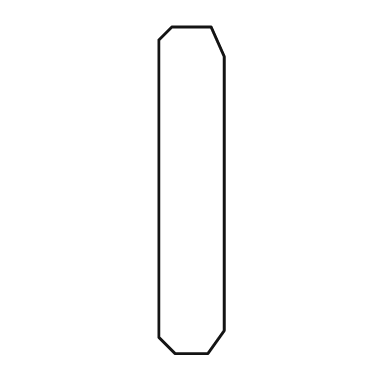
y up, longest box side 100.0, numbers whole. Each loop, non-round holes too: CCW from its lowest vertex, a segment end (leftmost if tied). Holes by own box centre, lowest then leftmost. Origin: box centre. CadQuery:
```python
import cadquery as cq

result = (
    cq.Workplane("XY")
    .moveTo(-5.0, -50.0)
    .lineTo(5.0, -50.0)
    .lineTo(10.0, -43.0)
    .lineTo(10.0, 41.0)
    .lineTo(6.0, 50.0)
    .lineTo(-6.0, 50.0)
    .lineTo(-10.0, 46.0)
    .lineTo(-10.0, -45.0)
    .close()
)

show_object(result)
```